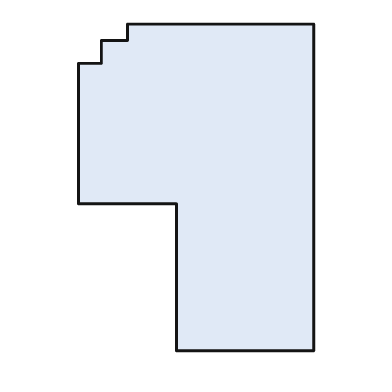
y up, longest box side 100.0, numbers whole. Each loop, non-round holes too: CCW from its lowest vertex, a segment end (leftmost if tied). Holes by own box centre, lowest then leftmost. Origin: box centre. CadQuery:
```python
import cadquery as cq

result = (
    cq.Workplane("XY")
    .moveTo(-6.0, -50.0)
    .lineTo(36.0, -50.0)
    .lineTo(36.0, 50.0)
    .lineTo(-21.0, 50.0)
    .lineTo(-21.0, 45.0)
    .lineTo(-29.0, 45.0)
    .lineTo(-29.0, 38.0)
    .lineTo(-36.0, 38.0)
    .lineTo(-36.0, -5.0)
    .lineTo(-6.0, -5.0)
    .close()
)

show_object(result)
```